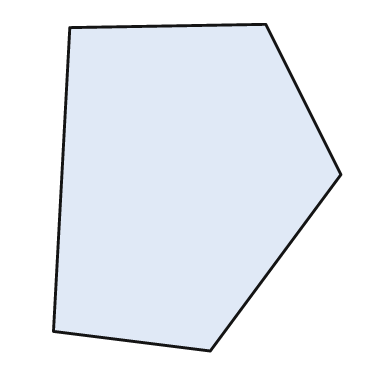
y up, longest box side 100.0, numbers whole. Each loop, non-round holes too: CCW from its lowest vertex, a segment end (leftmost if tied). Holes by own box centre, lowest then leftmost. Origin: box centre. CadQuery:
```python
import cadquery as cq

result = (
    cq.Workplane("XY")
    .moveTo(4.0, -50.0)
    .lineTo(44.0, 4.0)
    .lineTo(21.0, 50.0)
    .lineTo(-39.0, 49.0)
    .lineTo(-44.0, -44.0)
    .close()
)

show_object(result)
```